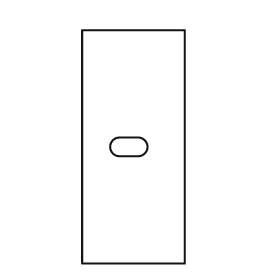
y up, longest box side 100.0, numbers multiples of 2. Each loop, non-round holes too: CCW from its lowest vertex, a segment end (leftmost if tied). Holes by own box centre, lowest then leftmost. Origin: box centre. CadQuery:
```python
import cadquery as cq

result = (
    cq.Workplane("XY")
    .moveTo(-22.0, -50.0)
    .lineTo(22.0, -50.0)
    .lineTo(22.0, 50.0)
    .lineTo(-22.0, 50.0)
    .close()
    .moveTo(-6.0, -4.0)
    .lineTo(2.0, -4.0)
    .threePointArc((6.0, 0.0), (2.0, 4.0))
    .lineTo(-6.0, 4.0)
    .threePointArc((-10.0, 0.0), (-6.0, -4.0))
    .close()
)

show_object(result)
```